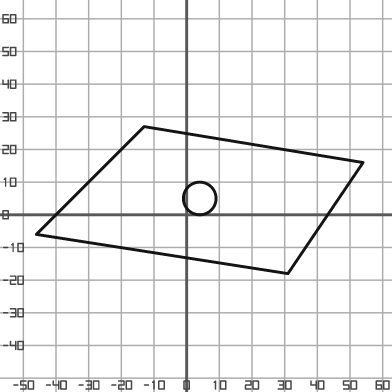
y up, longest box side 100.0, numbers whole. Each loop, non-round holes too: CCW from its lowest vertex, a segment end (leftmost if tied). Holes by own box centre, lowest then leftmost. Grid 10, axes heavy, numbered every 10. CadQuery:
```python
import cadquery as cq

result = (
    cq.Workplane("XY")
    .moveTo(31.0, -18.0)
    .lineTo(54.0, 16.0)
    .lineTo(-13.0, 27.0)
    .lineTo(-46.0, -6.0)
    .close()
    .moveTo(4.0, 5.0)
    .circle(5.0)
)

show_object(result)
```